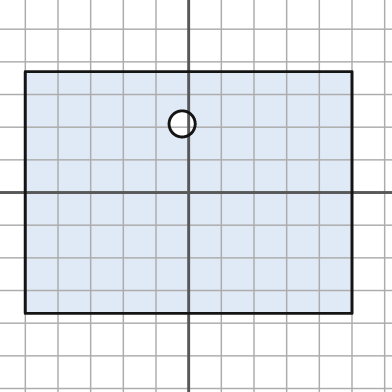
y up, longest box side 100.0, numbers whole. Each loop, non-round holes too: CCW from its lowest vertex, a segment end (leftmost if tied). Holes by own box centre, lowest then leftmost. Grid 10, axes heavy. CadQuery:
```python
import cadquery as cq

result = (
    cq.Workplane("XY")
    .moveTo(-50.0, -37.0)
    .lineTo(50.0, -37.0)
    .lineTo(50.0, 37.0)
    .lineTo(-50.0, 37.0)
    .close()
    .moveTo(-2.0, 21.0)
    .circle(4.0)
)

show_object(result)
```